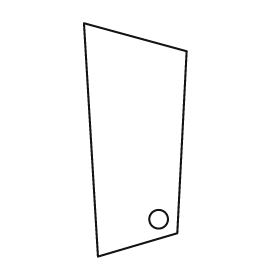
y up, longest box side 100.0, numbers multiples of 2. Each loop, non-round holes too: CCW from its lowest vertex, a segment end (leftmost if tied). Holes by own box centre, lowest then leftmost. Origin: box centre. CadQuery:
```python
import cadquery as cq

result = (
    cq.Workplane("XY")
    .moveTo(-16.0, -50.0)
    .lineTo(18.0, -40.0)
    .lineTo(22.0, 38.0)
    .lineTo(-22.0, 50.0)
    .close()
    .moveTo(10.0, -34.0)
    .circle(4.0)
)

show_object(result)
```